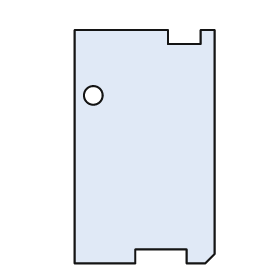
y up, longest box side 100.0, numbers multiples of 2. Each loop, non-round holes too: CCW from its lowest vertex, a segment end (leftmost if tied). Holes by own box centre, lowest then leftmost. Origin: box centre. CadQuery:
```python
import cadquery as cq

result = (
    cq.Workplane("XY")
    .moveTo(-30.0, -50.0)
    .lineTo(-4.0, -50.0)
    .lineTo(-4.0, -44.0)
    .lineTo(18.0, -44.0)
    .lineTo(18.0, -50.0)
    .lineTo(26.0, -50.0)
    .lineTo(30.0, -46.0)
    .lineTo(30.0, 50.0)
    .lineTo(24.0, 50.0)
    .lineTo(24.0, 44.0)
    .lineTo(10.0, 44.0)
    .lineTo(10.0, 50.0)
    .lineTo(-30.0, 50.0)
    .close()
    .moveTo(-22.0, 22.0)
    .circle(4.0)
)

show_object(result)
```